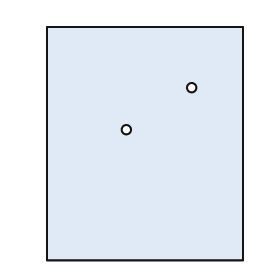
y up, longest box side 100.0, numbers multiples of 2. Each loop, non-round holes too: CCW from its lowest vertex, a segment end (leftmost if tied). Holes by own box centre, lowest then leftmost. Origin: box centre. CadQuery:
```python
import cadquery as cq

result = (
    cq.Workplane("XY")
    .moveTo(-42.0, -50.0)
    .lineTo(42.0, -50.0)
    .lineTo(42.0, 50.0)
    .lineTo(-42.0, 50.0)
    .close()
    .moveTo(-8.0, 6.0)
    .circle(2.0)
    .moveTo(20.0, 24.0)
    .circle(2.0)
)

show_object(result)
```